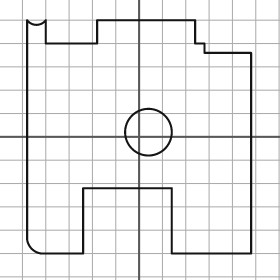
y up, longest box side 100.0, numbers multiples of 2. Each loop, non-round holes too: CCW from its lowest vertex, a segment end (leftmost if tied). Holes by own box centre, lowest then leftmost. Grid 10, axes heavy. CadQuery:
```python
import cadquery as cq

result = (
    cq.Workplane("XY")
    .moveTo(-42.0, -50.0)
    .lineTo(-24.0, -50.0)
    .lineTo(-24.0, -22.0)
    .lineTo(14.0, -22.0)
    .lineTo(14.0, -50.0)
    .lineTo(48.0, -50.0)
    .lineTo(48.0, 36.0)
    .lineTo(28.0, 36.0)
    .lineTo(28.0, 40.0)
    .lineTo(24.0, 40.0)
    .lineTo(24.0, 50.0)
    .lineTo(-18.0, 50.0)
    .lineTo(-18.0, 40.0)
    .lineTo(-40.0, 40.0)
    .lineTo(-40.0, 50.0)
    .threePointArc((-44.0, 48.0), (-48.0, 50.0))
    .lineTo(-48.0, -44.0)
    .threePointArc((-46.0, -48.0), (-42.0, -50.0))
    .close()
    .moveTo(4.0, 2.0)
    .circle(10.0)
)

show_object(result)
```